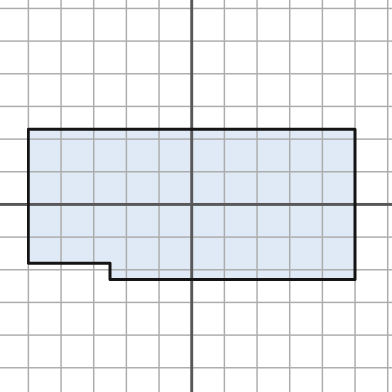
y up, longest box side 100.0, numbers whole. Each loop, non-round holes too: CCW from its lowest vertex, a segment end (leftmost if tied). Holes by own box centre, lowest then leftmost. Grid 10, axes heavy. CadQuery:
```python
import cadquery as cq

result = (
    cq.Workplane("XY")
    .moveTo(-25.0, -23.0)
    .lineTo(50.0, -23.0)
    .lineTo(50.0, 23.0)
    .lineTo(-50.0, 23.0)
    .lineTo(-50.0, -18.0)
    .lineTo(-25.0, -18.0)
    .close()
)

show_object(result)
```